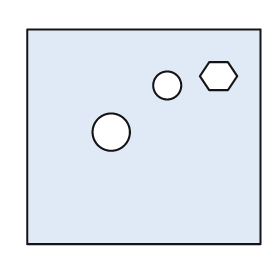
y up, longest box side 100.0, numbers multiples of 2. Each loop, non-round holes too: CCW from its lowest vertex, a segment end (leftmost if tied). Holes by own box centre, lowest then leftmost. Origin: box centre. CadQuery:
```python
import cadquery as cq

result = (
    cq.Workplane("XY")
    .moveTo(-50.0, -46.0)
    .lineTo(50.0, -46.0)
    .lineTo(50.0, 46.0)
    .lineTo(-50.0, 46.0)
    .close()
    .moveTo(-14.0, 2.0)
    .circle(8.0)
    .moveTo(10.0, 22.0)
    .circle(6.0)
    .moveTo(28.0, 20.0)
    .lineTo(36.0, 20.0)
    .lineTo(40.0, 26.0)
    .lineTo(36.0, 32.0)
    .lineTo(28.0, 32.0)
    .lineTo(24.0, 26.0)
    .close()
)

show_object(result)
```